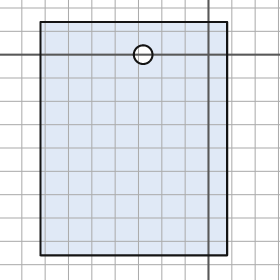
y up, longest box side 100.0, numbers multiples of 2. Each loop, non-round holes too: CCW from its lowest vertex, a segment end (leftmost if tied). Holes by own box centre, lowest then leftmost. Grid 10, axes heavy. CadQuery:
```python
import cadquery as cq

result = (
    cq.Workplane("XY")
    .moveTo(-72.0, -86.0)
    .lineTo(8.0, -86.0)
    .lineTo(8.0, 14.0)
    .lineTo(-72.0, 14.0)
    .close()
    .moveTo(-28.0, 0.0)
    .circle(4.0)
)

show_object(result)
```